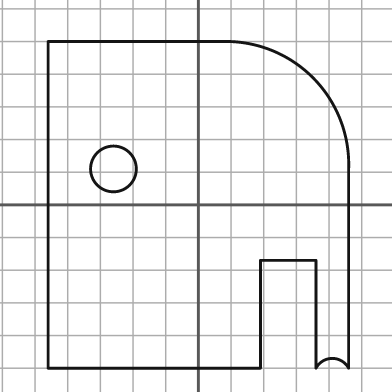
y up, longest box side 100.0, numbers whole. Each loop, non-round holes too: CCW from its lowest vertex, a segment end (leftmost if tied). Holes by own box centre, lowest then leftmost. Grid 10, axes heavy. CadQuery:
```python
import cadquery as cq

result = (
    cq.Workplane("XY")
    .moveTo(-46.0, -50.0)
    .lineTo(19.0, -50.0)
    .lineTo(19.0, -17.0)
    .lineTo(36.0, -17.0)
    .lineTo(36.0, -50.0)
    .threePointArc((41.0, -47.0), (46.0, -50.0))
    .lineTo(46.0, 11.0)
    .threePointArc((35.0, 39.0), (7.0, 50.0))
    .lineTo(-46.0, 50.0)
    .close()
    .moveTo(-26.0, 11.0)
    .circle(7.0)
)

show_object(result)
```